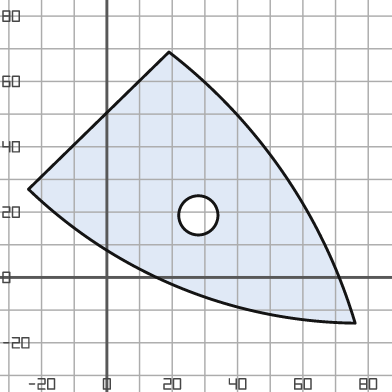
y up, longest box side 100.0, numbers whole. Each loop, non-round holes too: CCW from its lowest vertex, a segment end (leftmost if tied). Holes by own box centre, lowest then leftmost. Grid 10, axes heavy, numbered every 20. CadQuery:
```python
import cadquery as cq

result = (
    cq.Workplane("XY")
    .moveTo(76.0, -14.0)
    .threePointArc((54.0, 32.0), (19.0, 69.0))
    .lineTo(-24.0, 27.0)
    .threePointArc((22.0, -3.0), (76.0, -14.0))
    .close()
    .moveTo(28.0, 19.0)
    .circle(6.0)
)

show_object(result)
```